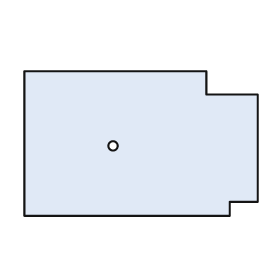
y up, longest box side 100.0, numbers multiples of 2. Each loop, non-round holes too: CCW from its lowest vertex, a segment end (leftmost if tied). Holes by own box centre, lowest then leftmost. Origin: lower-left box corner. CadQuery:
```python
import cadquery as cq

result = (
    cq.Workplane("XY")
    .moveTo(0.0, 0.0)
    .lineTo(88.0, 0.0)
    .lineTo(88.0, 6.0)
    .lineTo(100.0, 6.0)
    .lineTo(100.0, 52.0)
    .lineTo(78.0, 52.0)
    .lineTo(78.0, 62.0)
    .lineTo(0.0, 62.0)
    .close()
    .moveTo(38.0, 30.0)
    .circle(2.0)
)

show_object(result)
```